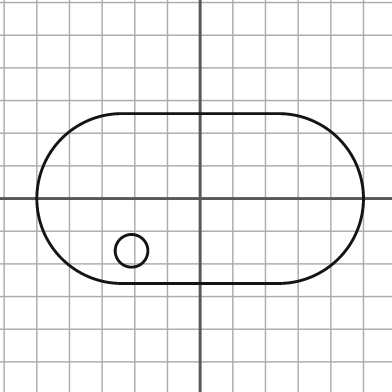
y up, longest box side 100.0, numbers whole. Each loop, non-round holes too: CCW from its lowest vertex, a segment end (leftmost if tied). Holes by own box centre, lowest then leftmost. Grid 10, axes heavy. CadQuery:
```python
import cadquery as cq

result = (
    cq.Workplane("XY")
    .moveTo(-24.0, -26.0)
    .lineTo(24.0, -26.0)
    .threePointArc((50.0, 0.0), (24.0, 26.0))
    .lineTo(-24.0, 26.0)
    .threePointArc((-50.0, 0.0), (-24.0, -26.0))
    .close()
    .moveTo(-21.0, -16.0)
    .circle(5.0)
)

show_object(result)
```